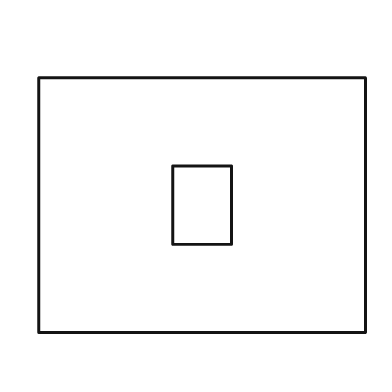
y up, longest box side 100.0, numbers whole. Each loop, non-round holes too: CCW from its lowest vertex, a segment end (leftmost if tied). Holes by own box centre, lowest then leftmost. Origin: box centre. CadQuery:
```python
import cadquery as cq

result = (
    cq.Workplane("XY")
    .moveTo(-50.0, -39.0)
    .lineTo(50.0, -39.0)
    .lineTo(50.0, 39.0)
    .lineTo(-50.0, 39.0)
    .close()
    .moveTo(-9.0, -12.0)
    .lineTo(9.0, -12.0)
    .lineTo(9.0, 12.0)
    .lineTo(-9.0, 12.0)
    .close()
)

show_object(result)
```